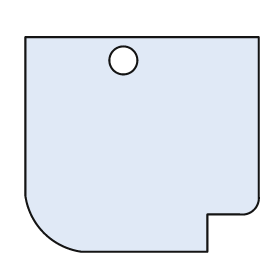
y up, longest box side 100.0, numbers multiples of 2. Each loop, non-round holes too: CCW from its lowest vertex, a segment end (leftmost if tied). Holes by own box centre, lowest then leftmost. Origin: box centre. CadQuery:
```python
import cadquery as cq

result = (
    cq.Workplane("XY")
    .moveTo(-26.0, -46.0)
    .lineTo(28.0, -46.0)
    .lineTo(28.0, -30.0)
    .lineTo(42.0, -30.0)
    .threePointArc((48.0, -28.0), (50.0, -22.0))
    .lineTo(50.0, 46.0)
    .lineTo(-50.0, 46.0)
    .lineTo(-50.0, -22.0)
    .threePointArc((-42.0, -38.0), (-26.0, -46.0))
    .close()
    .moveTo(-8.0, 36.0)
    .circle(6.0)
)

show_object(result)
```